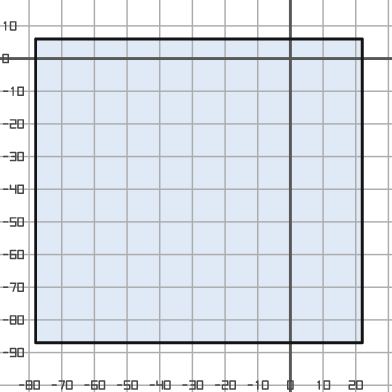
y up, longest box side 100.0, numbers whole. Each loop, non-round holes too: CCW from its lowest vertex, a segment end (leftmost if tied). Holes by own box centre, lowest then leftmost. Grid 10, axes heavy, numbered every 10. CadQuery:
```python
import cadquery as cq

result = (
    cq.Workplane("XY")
    .moveTo(-78.0, -87.0)
    .lineTo(22.0, -87.0)
    .lineTo(22.0, 6.0)
    .lineTo(-78.0, 6.0)
    .close()
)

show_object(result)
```